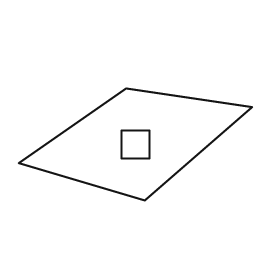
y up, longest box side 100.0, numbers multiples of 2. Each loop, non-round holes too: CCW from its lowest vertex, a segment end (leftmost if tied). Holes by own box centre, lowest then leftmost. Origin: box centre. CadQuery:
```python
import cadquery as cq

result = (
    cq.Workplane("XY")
    .moveTo(4.0, -24.0)
    .lineTo(50.0, 16.0)
    .lineTo(-4.0, 24.0)
    .lineTo(-50.0, -8.0)
    .close()
    .moveTo(-6.0, -6.0)
    .lineTo(6.0, -6.0)
    .lineTo(6.0, 6.0)
    .lineTo(-6.0, 6.0)
    .close()
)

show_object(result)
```